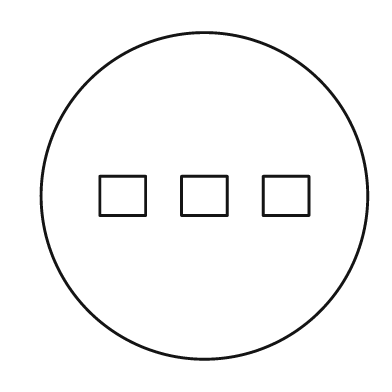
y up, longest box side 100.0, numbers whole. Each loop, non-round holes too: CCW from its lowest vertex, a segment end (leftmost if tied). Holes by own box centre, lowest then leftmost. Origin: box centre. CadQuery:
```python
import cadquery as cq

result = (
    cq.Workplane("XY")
    .moveTo(0.0, 0.0)
    .circle(50.0)
    .moveTo(-32.0, -6.0)
    .lineTo(-18.0, -6.0)
    .lineTo(-18.0, 6.0)
    .lineTo(-32.0, 6.0)
    .close()
    .moveTo(-7.0, -6.0)
    .lineTo(7.0, -6.0)
    .lineTo(7.0, 6.0)
    .lineTo(-7.0, 6.0)
    .close()
    .moveTo(18.0, -6.0)
    .lineTo(32.0, -6.0)
    .lineTo(32.0, 6.0)
    .lineTo(18.0, 6.0)
    .close()
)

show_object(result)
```